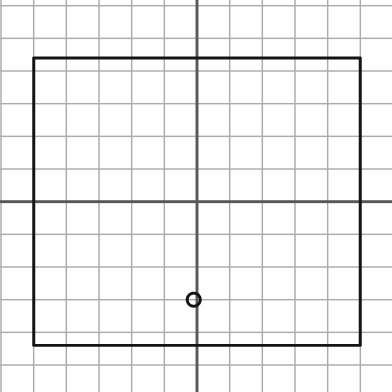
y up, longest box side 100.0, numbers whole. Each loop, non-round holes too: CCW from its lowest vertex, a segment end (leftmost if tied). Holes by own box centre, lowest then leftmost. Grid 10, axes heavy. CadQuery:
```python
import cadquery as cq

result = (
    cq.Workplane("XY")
    .moveTo(-50.0, -44.0)
    .lineTo(50.0, -44.0)
    .lineTo(50.0, 44.0)
    .lineTo(-50.0, 44.0)
    .close()
    .moveTo(-1.0, -30.0)
    .circle(2.0)
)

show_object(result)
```